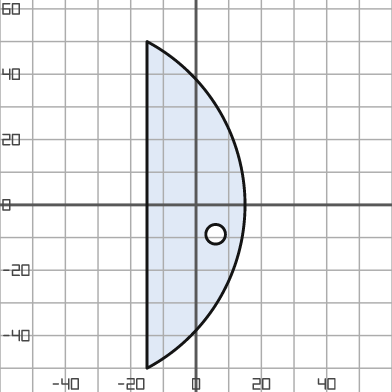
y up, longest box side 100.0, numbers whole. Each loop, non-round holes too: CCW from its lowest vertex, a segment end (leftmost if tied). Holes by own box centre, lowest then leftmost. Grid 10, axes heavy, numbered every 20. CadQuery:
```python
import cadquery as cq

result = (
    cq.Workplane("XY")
    .moveTo(-15.0, -50.0)
    .threePointArc((15.0, 0.0), (-15.0, 50.0))
    .close()
    .moveTo(6.0, -9.0)
    .circle(3.0)
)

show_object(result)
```